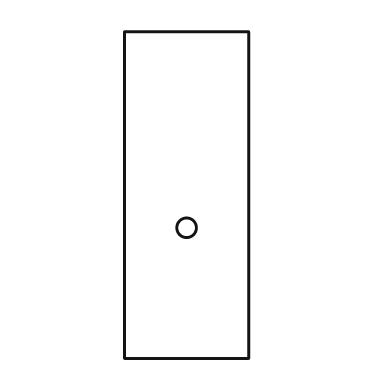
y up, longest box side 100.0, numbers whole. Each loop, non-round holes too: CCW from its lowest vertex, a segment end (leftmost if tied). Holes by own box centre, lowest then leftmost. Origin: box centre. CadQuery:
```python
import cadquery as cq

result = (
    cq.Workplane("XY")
    .moveTo(-19.0, -50.0)
    .lineTo(19.0, -50.0)
    .lineTo(19.0, 50.0)
    .lineTo(-19.0, 50.0)
    .close()
    .moveTo(0.0, -10.0)
    .circle(3.0)
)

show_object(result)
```